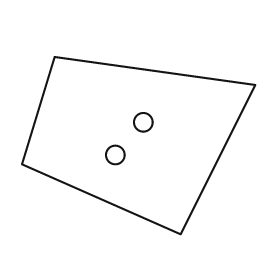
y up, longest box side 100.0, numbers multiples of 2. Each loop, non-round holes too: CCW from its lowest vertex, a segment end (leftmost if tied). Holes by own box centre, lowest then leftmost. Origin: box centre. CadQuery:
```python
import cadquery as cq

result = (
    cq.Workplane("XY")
    .moveTo(18.0, -38.0)
    .lineTo(50.0, 26.0)
    .lineTo(-36.0, 38.0)
    .lineTo(-50.0, -8.0)
    .close()
    .moveTo(-10.0, -4.0)
    .circle(4.0)
    .moveTo(2.0, 10.0)
    .circle(4.0)
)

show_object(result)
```